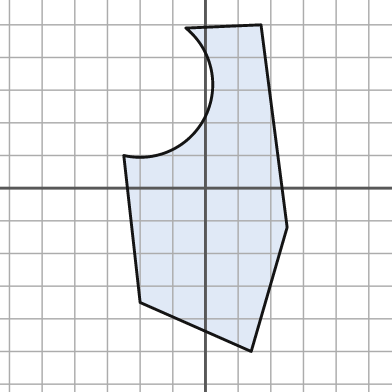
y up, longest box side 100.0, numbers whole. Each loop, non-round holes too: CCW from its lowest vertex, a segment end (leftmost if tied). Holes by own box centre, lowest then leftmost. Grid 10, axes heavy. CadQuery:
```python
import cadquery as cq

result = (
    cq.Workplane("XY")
    .moveTo(14.0, -50.0)
    .lineTo(25.0, -12.0)
    .lineTo(17.0, 50.0)
    .lineTo(-6.0, 49.0)
    .threePointArc((0.0, 22.0), (-25.0, 10.0))
    .lineTo(-20.0, -35.0)
    .close()
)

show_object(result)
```